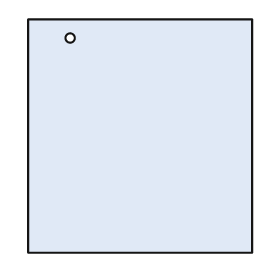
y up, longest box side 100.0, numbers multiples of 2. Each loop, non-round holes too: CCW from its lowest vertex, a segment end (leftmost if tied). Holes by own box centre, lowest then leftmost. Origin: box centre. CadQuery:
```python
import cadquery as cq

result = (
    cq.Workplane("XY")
    .moveTo(-48.0, -50.0)
    .lineTo(48.0, -50.0)
    .lineTo(48.0, 50.0)
    .lineTo(-48.0, 50.0)
    .close()
    .moveTo(-30.0, 42.0)
    .circle(2.0)
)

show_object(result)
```